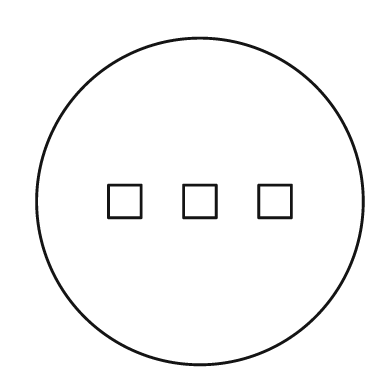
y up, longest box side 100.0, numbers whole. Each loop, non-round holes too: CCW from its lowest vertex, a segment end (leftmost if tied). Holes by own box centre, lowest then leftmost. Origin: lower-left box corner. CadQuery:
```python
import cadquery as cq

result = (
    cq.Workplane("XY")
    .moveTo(50.0, 50.0)
    .circle(50.0)
    .moveTo(22.0, 45.0)
    .lineTo(32.0, 45.0)
    .lineTo(32.0, 55.0)
    .lineTo(22.0, 55.0)
    .close()
    .moveTo(45.0, 45.0)
    .lineTo(55.0, 45.0)
    .lineTo(55.0, 55.0)
    .lineTo(45.0, 55.0)
    .close()
    .moveTo(68.0, 45.0)
    .lineTo(78.0, 45.0)
    .lineTo(78.0, 55.0)
    .lineTo(68.0, 55.0)
    .close()
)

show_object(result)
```